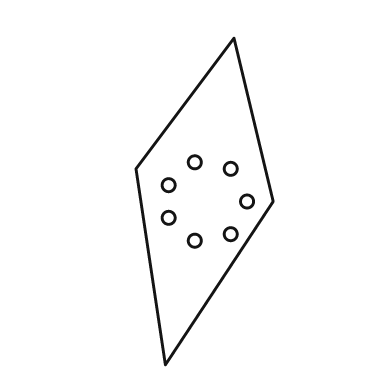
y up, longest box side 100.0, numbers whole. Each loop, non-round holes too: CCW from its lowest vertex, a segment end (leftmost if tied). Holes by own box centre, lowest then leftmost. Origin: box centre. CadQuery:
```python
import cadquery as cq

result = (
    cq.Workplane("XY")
    .moveTo(-12.0, -50.0)
    .lineTo(21.0, 0.0)
    .lineTo(9.0, 50.0)
    .lineTo(-21.0, 10.0)
    .close()
    .moveTo(-3.0, -12.0)
    .circle(2.0)
    .moveTo(8.0, -10.0)
    .circle(2.0)
    .moveTo(-11.0, -5.0)
    .circle(2.0)
    .moveTo(13.0, 0.0)
    .circle(2.0)
    .moveTo(-11.0, 5.0)
    .circle(2.0)
    .moveTo(8.0, 10.0)
    .circle(2.0)
    .moveTo(-3.0, 12.0)
    .circle(2.0)
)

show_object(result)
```